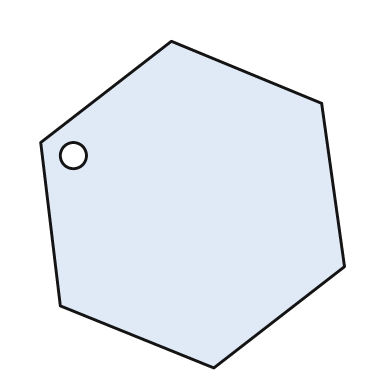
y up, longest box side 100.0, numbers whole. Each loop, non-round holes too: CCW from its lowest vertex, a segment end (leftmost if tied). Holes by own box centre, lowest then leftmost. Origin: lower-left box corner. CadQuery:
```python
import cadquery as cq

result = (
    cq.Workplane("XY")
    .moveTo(53.0, 0.0)
    .lineTo(93.0, 31.0)
    .lineTo(86.0, 81.0)
    .lineTo(40.0, 100.0)
    .lineTo(0.0, 69.0)
    .lineTo(6.0, 19.0)
    .close()
    .moveTo(10.0, 65.0)
    .circle(4.0)
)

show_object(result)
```